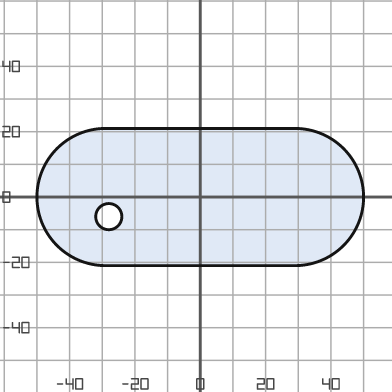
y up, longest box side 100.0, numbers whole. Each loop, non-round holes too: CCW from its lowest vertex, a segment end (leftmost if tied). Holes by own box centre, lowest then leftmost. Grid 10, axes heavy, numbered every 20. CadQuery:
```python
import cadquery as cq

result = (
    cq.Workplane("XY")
    .moveTo(-29.0, -21.0)
    .lineTo(29.0, -21.0)
    .threePointArc((50.0, 0.0), (29.0, 21.0))
    .lineTo(-29.0, 21.0)
    .threePointArc((-50.0, 0.0), (-29.0, -21.0))
    .close()
    .moveTo(-28.0, -6.0)
    .circle(4.0)
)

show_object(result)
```